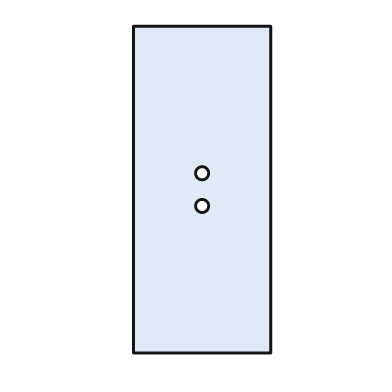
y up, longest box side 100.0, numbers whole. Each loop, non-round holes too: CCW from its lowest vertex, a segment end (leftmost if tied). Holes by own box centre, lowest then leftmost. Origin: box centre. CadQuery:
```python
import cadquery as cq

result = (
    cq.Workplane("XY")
    .moveTo(-21.0, -50.0)
    .lineTo(21.0, -50.0)
    .lineTo(21.0, 50.0)
    .lineTo(-21.0, 50.0)
    .close()
    .moveTo(0.0, -5.0)
    .circle(2.0)
    .moveTo(0.0, 5.0)
    .circle(2.0)
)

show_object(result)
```